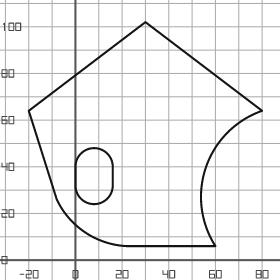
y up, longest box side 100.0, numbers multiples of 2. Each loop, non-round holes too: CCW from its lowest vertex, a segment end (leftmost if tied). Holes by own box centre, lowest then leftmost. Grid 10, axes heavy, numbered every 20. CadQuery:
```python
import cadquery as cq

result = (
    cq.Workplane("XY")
    .moveTo(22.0, 6.0)
    .lineTo(60.0, 6.0)
    .threePointArc((56.0, 40.0), (80.0, 64.0))
    .lineTo(30.0, 102.0)
    .lineTo(-20.0, 64.0)
    .lineTo(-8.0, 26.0)
    .threePointArc((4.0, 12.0), (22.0, 6.0))
    .close()
    .moveTo(0.0, 32.0)
    .threePointArc((8.0, 24.0), (16.0, 32.0))
    .lineTo(16.0, 40.0)
    .threePointArc((8.0, 48.0), (0.0, 40.0))
    .close()
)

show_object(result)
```